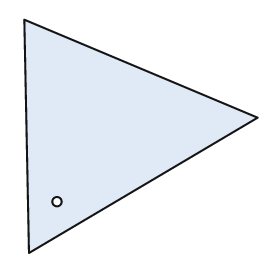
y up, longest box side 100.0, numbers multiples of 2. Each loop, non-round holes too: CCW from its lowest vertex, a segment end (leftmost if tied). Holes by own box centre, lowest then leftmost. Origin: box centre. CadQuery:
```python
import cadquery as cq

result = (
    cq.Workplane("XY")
    .moveTo(-48.0, -50.0)
    .lineTo(50.0, 8.0)
    .lineTo(-50.0, 50.0)
    .close()
    .moveTo(-36.0, -28.0)
    .circle(2.0)
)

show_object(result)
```